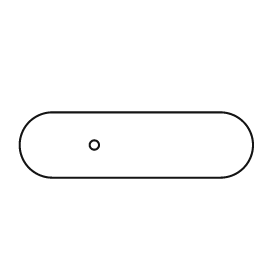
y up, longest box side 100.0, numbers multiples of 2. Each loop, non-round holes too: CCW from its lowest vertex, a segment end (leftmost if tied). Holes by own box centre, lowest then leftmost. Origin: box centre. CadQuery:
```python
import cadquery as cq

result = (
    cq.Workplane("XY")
    .moveTo(-36.0, -14.0)
    .lineTo(36.0, -14.0)
    .threePointArc((50.0, 0.0), (36.0, 14.0))
    .lineTo(-36.0, 14.0)
    .threePointArc((-50.0, 0.0), (-36.0, -14.0))
    .close()
    .moveTo(-18.0, 0.0)
    .circle(2.0)
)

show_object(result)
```